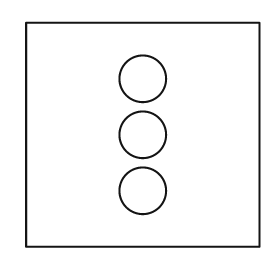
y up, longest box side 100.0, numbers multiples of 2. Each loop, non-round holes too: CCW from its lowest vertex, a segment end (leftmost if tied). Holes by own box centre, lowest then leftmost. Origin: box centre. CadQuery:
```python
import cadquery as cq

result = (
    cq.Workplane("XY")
    .moveTo(-50.0, -48.0)
    .lineTo(50.0, -48.0)
    .lineTo(50.0, 48.0)
    .lineTo(-50.0, 48.0)
    .close()
    .moveTo(0.0, -24.0)
    .circle(10.0)
    .moveTo(0.0, 0.0)
    .circle(10.0)
    .moveTo(0.0, 24.0)
    .circle(10.0)
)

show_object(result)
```